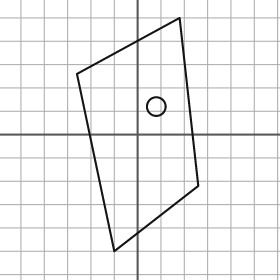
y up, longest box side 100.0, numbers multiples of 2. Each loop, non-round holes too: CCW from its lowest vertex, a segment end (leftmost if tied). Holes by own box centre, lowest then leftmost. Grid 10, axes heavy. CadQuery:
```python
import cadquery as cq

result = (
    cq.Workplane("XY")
    .moveTo(-10.0, -50.0)
    .lineTo(26.0, -22.0)
    .lineTo(18.0, 50.0)
    .lineTo(-26.0, 26.0)
    .close()
    .moveTo(8.0, 12.0)
    .circle(4.0)
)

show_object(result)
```